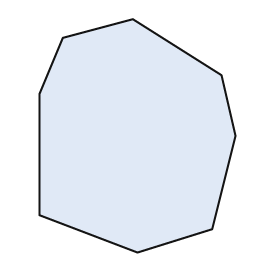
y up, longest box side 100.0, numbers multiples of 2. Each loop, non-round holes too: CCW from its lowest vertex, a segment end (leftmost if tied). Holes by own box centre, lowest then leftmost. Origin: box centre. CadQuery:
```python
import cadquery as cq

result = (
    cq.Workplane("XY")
    .moveTo(0.0, -50.0)
    .lineTo(32.0, -40.0)
    .lineTo(42.0, 0.0)
    .lineTo(36.0, 26.0)
    .lineTo(-2.0, 50.0)
    .lineTo(-32.0, 42.0)
    .lineTo(-42.0, 18.0)
    .lineTo(-42.0, -34.0)
    .close()
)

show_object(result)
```